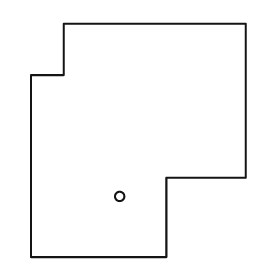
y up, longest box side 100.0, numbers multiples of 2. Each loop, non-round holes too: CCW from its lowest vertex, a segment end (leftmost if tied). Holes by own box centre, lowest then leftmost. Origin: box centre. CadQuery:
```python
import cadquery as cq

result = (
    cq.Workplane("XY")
    .moveTo(-46.0, -50.0)
    .lineTo(12.0, -50.0)
    .lineTo(12.0, -16.0)
    .lineTo(46.0, -16.0)
    .lineTo(46.0, 50.0)
    .lineTo(-32.0, 50.0)
    .lineTo(-32.0, 28.0)
    .lineTo(-46.0, 28.0)
    .close()
    .moveTo(-8.0, -24.0)
    .circle(2.0)
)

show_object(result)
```